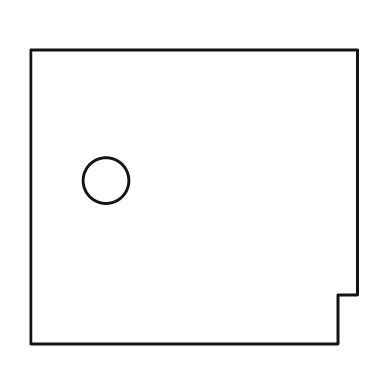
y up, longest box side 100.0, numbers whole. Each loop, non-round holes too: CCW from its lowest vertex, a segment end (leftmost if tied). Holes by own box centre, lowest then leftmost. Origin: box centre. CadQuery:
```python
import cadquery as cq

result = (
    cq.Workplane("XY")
    .moveTo(-50.0, -45.0)
    .lineTo(44.0, -45.0)
    .lineTo(44.0, -30.0)
    .lineTo(50.0, -30.0)
    .lineTo(50.0, 45.0)
    .lineTo(-50.0, 45.0)
    .close()
    .moveTo(-27.0, 5.0)
    .circle(7.0)
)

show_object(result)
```